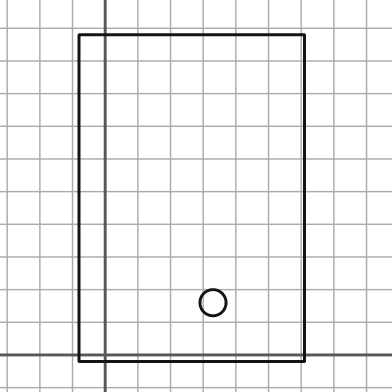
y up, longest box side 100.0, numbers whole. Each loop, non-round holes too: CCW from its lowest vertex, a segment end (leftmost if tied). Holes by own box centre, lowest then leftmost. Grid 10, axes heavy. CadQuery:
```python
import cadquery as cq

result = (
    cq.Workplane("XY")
    .moveTo(-8.0, -2.0)
    .lineTo(61.0, -2.0)
    .lineTo(61.0, 98.0)
    .lineTo(-8.0, 98.0)
    .close()
    .moveTo(33.0, 16.0)
    .circle(4.0)
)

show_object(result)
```